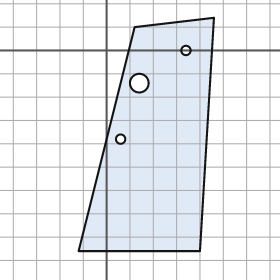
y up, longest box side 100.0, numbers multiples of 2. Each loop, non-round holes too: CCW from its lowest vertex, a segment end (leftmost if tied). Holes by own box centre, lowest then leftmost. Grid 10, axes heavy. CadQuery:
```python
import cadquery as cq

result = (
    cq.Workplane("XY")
    .moveTo(-12.0, -86.0)
    .lineTo(40.0, -86.0)
    .lineTo(46.0, 14.0)
    .lineTo(12.0, 10.0)
    .close()
    .moveTo(6.0, -38.0)
    .circle(2.0)
    .moveTo(14.0, -14.0)
    .circle(4.0)
    .moveTo(34.0, 0.0)
    .circle(2.0)
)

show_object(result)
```